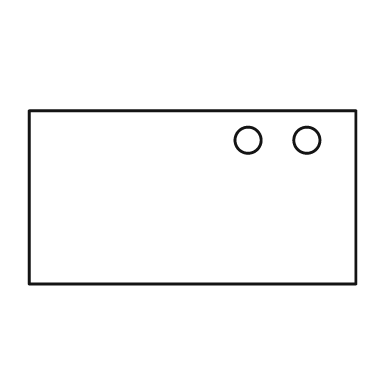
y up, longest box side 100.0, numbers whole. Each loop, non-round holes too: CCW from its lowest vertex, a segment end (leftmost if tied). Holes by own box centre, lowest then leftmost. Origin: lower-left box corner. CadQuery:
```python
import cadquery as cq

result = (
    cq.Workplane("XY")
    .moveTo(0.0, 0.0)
    .lineTo(100.0, 0.0)
    .lineTo(100.0, 53.0)
    .lineTo(0.0, 53.0)
    .close()
    .moveTo(67.0, 44.0)
    .circle(4.0)
    .moveTo(85.0, 44.0)
    .circle(4.0)
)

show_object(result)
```